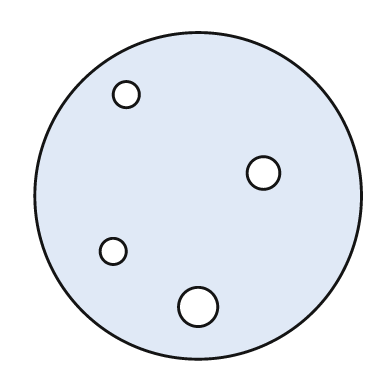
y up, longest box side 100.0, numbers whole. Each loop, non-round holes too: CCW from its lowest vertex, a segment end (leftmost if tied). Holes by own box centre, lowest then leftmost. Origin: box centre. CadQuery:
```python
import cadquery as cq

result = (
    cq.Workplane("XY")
    .moveTo(0.0, 0.0)
    .circle(50.0)
    .moveTo(0.0, -34.0)
    .circle(6.0)
    .moveTo(-26.0, -17.0)
    .circle(4.0)
    .moveTo(20.0, 7.0)
    .circle(5.0)
    .moveTo(-22.0, 31.0)
    .circle(4.0)
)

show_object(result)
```